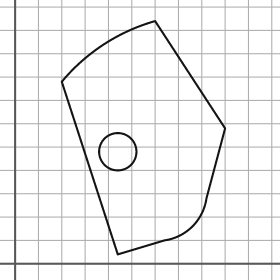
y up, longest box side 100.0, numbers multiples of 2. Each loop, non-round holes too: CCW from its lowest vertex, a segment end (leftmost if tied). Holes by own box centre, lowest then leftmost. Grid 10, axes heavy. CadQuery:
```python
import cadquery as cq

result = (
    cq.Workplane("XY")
    .moveTo(44.0, 4.0)
    .lineTo(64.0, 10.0)
    .threePointArc((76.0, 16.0), (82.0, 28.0))
    .lineTo(90.0, 58.0)
    .lineTo(60.0, 104.0)
    .threePointArc((38.0, 94.0), (20.0, 78.0))
    .close()
    .moveTo(44.0, 48.0)
    .circle(8.0)
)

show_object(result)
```